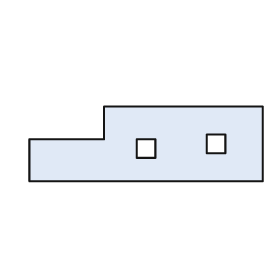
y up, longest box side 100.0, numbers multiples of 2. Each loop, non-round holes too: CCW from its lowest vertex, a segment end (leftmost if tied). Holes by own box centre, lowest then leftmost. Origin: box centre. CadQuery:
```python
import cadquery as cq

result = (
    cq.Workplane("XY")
    .moveTo(-50.0, -16.0)
    .lineTo(50.0, -16.0)
    .lineTo(50.0, 16.0)
    .lineTo(-18.0, 16.0)
    .lineTo(-18.0, 2.0)
    .lineTo(-50.0, 2.0)
    .close()
    .moveTo(-4.0, -6.0)
    .lineTo(4.0, -6.0)
    .lineTo(4.0, 2.0)
    .lineTo(-4.0, 2.0)
    .close()
    .moveTo(26.0, -4.0)
    .lineTo(34.0, -4.0)
    .lineTo(34.0, 4.0)
    .lineTo(26.0, 4.0)
    .close()
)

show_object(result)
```